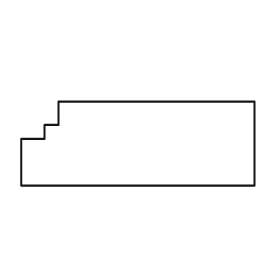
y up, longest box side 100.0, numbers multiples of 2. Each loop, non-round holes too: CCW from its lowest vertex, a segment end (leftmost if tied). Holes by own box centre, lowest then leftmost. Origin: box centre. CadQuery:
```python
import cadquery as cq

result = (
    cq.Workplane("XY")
    .moveTo(-50.0, -18.0)
    .lineTo(50.0, -18.0)
    .lineTo(50.0, 18.0)
    .lineTo(-34.0, 18.0)
    .lineTo(-34.0, 8.0)
    .lineTo(-40.0, 8.0)
    .lineTo(-40.0, 2.0)
    .lineTo(-50.0, 2.0)
    .close()
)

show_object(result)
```